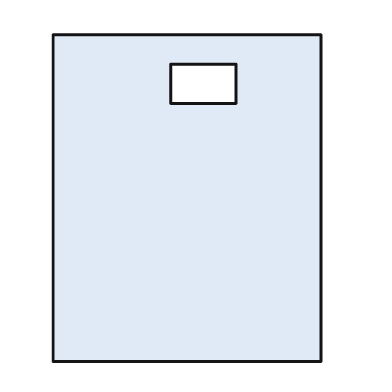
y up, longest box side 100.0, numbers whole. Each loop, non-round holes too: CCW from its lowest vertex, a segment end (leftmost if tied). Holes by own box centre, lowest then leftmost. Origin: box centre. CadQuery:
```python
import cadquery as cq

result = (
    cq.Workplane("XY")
    .moveTo(-41.0, -50.0)
    .lineTo(41.0, -50.0)
    .lineTo(41.0, 50.0)
    .lineTo(-41.0, 50.0)
    .close()
    .moveTo(-5.0, 29.0)
    .lineTo(15.0, 29.0)
    .lineTo(15.0, 41.0)
    .lineTo(-5.0, 41.0)
    .close()
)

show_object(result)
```